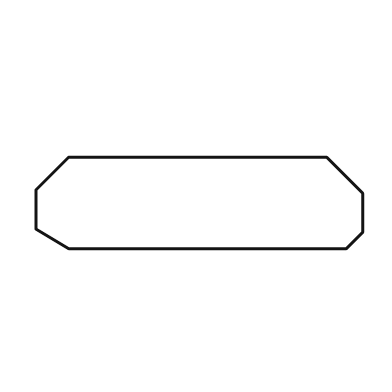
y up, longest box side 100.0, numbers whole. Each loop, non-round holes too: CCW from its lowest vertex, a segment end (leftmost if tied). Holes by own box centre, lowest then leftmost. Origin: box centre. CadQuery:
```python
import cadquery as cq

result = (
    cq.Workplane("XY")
    .moveTo(-40.0, -14.0)
    .lineTo(45.0, -14.0)
    .lineTo(50.0, -9.0)
    .lineTo(50.0, 3.0)
    .lineTo(39.0, 14.0)
    .lineTo(-40.0, 14.0)
    .lineTo(-50.0, 4.0)
    .lineTo(-50.0, -8.0)
    .close()
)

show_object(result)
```